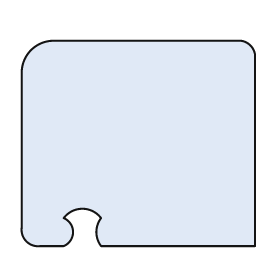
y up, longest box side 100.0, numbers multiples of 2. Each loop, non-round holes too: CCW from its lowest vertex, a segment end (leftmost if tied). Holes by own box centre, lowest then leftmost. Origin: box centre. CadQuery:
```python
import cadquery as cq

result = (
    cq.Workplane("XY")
    .moveTo(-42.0, -44.0)
    .lineTo(-32.0, -44.0)
    .threePointArc((-28.0, -38.0), (-32.0, -32.0))
    .threePointArc((-24.0, -28.0), (-16.0, -32.0))
    .threePointArc((-18.0, -38.0), (-16.0, -44.0))
    .lineTo(50.0, -44.0)
    .lineTo(50.0, 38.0)
    .threePointArc((48.0, 42.0), (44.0, 44.0))
    .lineTo(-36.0, 44.0)
    .threePointArc((-46.0, 40.0), (-50.0, 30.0))
    .lineTo(-50.0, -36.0)
    .threePointArc((-48.0, -42.0), (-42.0, -44.0))
    .close()
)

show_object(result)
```